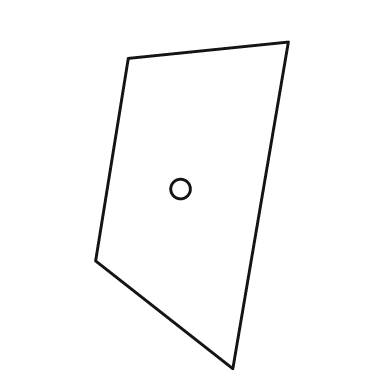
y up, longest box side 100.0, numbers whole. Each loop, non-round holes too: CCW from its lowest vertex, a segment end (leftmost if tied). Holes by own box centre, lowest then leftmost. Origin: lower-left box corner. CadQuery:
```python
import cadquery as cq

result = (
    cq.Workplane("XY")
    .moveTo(42.0, 0.0)
    .lineTo(59.0, 100.0)
    .lineTo(10.0, 95.0)
    .lineTo(0.0, 33.0)
    .close()
    .moveTo(26.0, 55.0)
    .circle(3.0)
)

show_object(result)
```